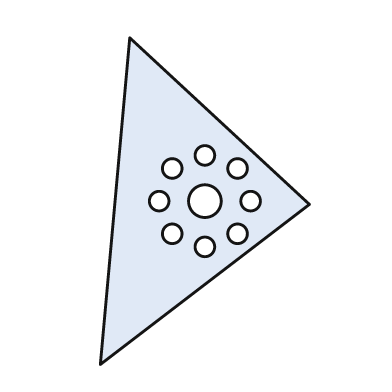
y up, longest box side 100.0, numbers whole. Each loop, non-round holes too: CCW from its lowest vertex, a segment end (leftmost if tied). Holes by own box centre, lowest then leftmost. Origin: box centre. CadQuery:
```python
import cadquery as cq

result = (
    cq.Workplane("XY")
    .moveTo(-32.0, -50.0)
    .lineTo(32.0, -1.0)
    .lineTo(-23.0, 50.0)
    .close()
    .moveTo(0.0, -14.0)
    .circle(3.0)
    .moveTo(-10.0, -10.0)
    .circle(3.0)
    .moveTo(10.0, -10.0)
    .circle(3.0)
    .moveTo(-14.0, 0.0)
    .circle(3.0)
    .moveTo(0.0, 0.0)
    .circle(5.0)
    .moveTo(14.0, 0.0)
    .circle(3.0)
    .moveTo(-10.0, 10.0)
    .circle(3.0)
    .moveTo(10.0, 10.0)
    .circle(3.0)
    .moveTo(0.0, 14.0)
    .circle(3.0)
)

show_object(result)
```